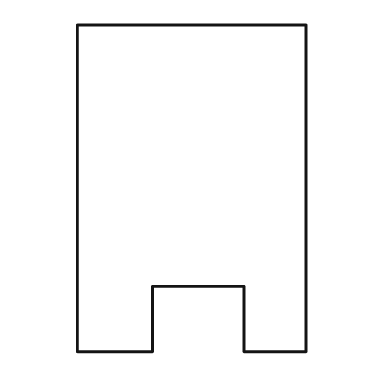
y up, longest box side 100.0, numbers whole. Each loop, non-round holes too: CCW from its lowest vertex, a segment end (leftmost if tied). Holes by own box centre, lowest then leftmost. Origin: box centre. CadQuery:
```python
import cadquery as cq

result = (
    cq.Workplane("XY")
    .moveTo(-35.0, -50.0)
    .lineTo(-12.0, -50.0)
    .lineTo(-12.0, -30.0)
    .lineTo(16.0, -30.0)
    .lineTo(16.0, -50.0)
    .lineTo(35.0, -50.0)
    .lineTo(35.0, 50.0)
    .lineTo(-35.0, 50.0)
    .close()
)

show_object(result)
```